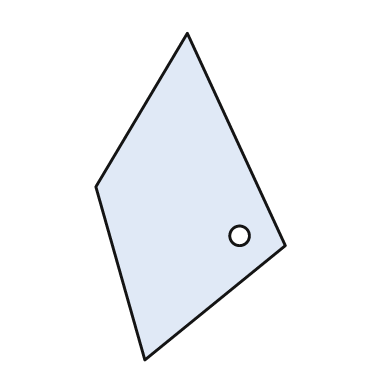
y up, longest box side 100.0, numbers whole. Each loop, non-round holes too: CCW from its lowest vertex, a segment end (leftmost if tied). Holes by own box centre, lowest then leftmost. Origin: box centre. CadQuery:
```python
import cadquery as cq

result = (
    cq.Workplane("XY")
    .moveTo(-14.0, -50.0)
    .lineTo(29.0, -15.0)
    .lineTo(-1.0, 50.0)
    .lineTo(-29.0, 3.0)
    .close()
    .moveTo(15.0, -12.0)
    .circle(3.0)
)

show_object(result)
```